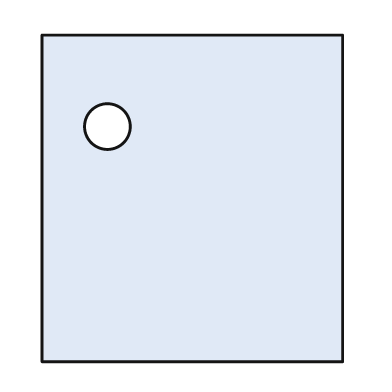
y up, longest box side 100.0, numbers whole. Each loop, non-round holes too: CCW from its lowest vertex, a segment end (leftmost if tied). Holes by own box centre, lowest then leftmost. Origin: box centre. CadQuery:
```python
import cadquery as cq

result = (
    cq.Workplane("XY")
    .moveTo(-46.0, -50.0)
    .lineTo(46.0, -50.0)
    .lineTo(46.0, 50.0)
    .lineTo(-46.0, 50.0)
    .close()
    .moveTo(-26.0, 22.0)
    .circle(7.0)
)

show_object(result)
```